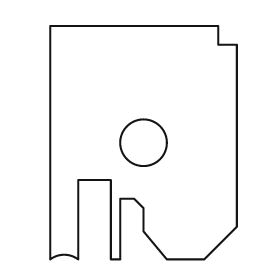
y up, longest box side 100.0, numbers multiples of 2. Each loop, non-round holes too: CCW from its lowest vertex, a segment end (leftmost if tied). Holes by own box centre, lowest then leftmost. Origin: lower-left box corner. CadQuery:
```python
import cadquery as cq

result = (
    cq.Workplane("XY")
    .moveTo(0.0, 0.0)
    .threePointArc((6.0, 2.0), (12.0, 0.0))
    .lineTo(12.0, 34.0)
    .lineTo(26.0, 34.0)
    .lineTo(26.0, 0.0)
    .lineTo(30.0, 0.0)
    .lineTo(30.0, 26.0)
    .lineTo(36.0, 26.0)
    .lineTo(40.0, 22.0)
    .lineTo(40.0, 12.0)
    .lineTo(50.0, 0.0)
    .lineTo(66.0, 0.0)
    .lineTo(80.0, 14.0)
    .lineTo(80.0, 92.0)
    .lineTo(72.0, 92.0)
    .lineTo(72.0, 100.0)
    .lineTo(0.0, 100.0)
    .close()
    .moveTo(40.0, 50.0)
    .circle(10.0)
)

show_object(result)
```